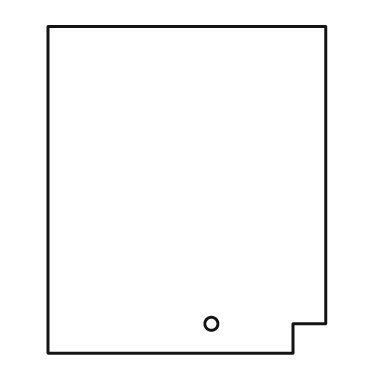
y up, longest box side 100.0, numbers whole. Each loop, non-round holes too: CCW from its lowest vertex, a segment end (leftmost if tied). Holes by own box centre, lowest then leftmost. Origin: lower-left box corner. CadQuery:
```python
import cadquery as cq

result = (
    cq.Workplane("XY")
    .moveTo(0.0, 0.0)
    .lineTo(75.0, 0.0)
    .lineTo(75.0, 9.0)
    .lineTo(85.0, 9.0)
    .lineTo(85.0, 100.0)
    .lineTo(0.0, 100.0)
    .close()
    .moveTo(50.0, 9.0)
    .circle(2.0)
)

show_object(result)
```